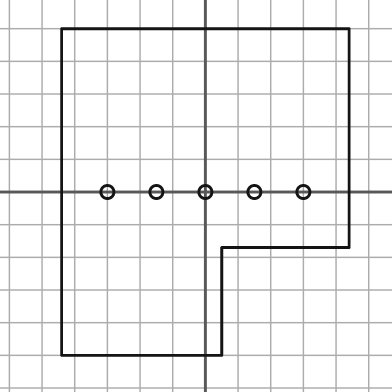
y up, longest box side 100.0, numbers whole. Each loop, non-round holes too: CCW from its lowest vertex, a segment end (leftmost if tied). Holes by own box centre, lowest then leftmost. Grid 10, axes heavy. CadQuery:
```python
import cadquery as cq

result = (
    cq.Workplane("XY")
    .moveTo(-44.0, -50.0)
    .lineTo(5.0, -50.0)
    .lineTo(5.0, -17.0)
    .lineTo(44.0, -17.0)
    .lineTo(44.0, 50.0)
    .lineTo(-44.0, 50.0)
    .close()
    .moveTo(-30.0, 0.0)
    .circle(2.0)
    .moveTo(-15.0, 0.0)
    .circle(2.0)
    .moveTo(0.0, 0.0)
    .circle(2.0)
    .moveTo(15.0, 0.0)
    .circle(2.0)
    .moveTo(30.0, 0.0)
    .circle(2.0)
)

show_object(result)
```